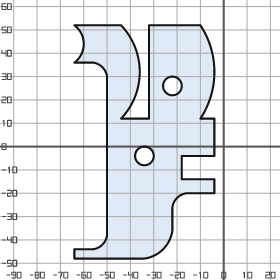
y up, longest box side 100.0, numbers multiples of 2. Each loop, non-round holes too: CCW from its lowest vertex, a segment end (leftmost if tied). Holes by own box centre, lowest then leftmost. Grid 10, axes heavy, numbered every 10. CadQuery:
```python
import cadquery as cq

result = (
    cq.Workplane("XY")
    .moveTo(-64.0, -48.0)
    .lineTo(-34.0, -48.0)
    .threePointArc((-26.0, -44.0), (-22.0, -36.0))
    .lineTo(-22.0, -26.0)
    .threePointArc((-20.0, -22.0), (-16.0, -20.0))
    .lineTo(-4.0, -20.0)
    .lineTo(-4.0, -14.0)
    .lineTo(-18.0, -14.0)
    .lineTo(-18.0, -4.0)
    .lineTo(-4.0, -4.0)
    .lineTo(-4.0, 12.0)
    .lineTo(-10.0, 12.0)
    .threePointArc((-4.0, 32.0), (-10.0, 52.0))
    .lineTo(-32.0, 52.0)
    .lineTo(-32.0, 12.0)
    .lineTo(-44.0, 12.0)
    .threePointArc((-36.0, 32.0), (-44.0, 52.0))
    .lineTo(-64.0, 52.0)
    .threePointArc((-60.0, 44.0), (-64.0, 36.0))
    .lineTo(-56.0, 36.0)
    .threePointArc((-52.0, 34.0), (-50.0, 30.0))
    .lineTo(-50.0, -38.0)
    .threePointArc((-52.0, -42.0), (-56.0, -44.0))
    .lineTo(-64.0, -44.0)
    .close()
    .moveTo(-34.0, -4.0)
    .circle(4.0)
    .moveTo(-22.0, 26.0)
    .circle(4.0)
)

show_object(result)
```